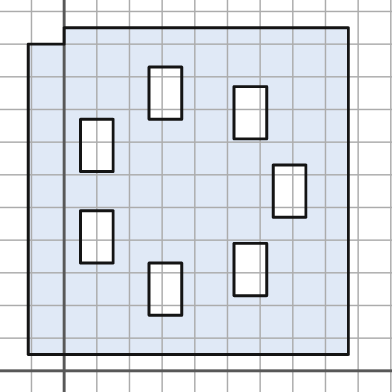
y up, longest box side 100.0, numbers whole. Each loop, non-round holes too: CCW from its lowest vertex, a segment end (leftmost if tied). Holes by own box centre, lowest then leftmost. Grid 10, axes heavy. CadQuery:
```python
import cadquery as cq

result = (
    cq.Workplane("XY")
    .moveTo(-11.0, 5.0)
    .lineTo(87.0, 5.0)
    .lineTo(87.0, 105.0)
    .lineTo(0.0, 105.0)
    .lineTo(0.0, 100.0)
    .lineTo(-11.0, 100.0)
    .close()
    .moveTo(26.0, 17.0)
    .lineTo(36.0, 17.0)
    .lineTo(36.0, 33.0)
    .lineTo(26.0, 33.0)
    .close()
    .moveTo(52.0, 23.0)
    .lineTo(62.0, 23.0)
    .lineTo(62.0, 39.0)
    .lineTo(52.0, 39.0)
    .close()
    .moveTo(5.0, 33.0)
    .lineTo(15.0, 33.0)
    .lineTo(15.0, 49.0)
    .lineTo(5.0, 49.0)
    .close()
    .moveTo(64.0, 47.0)
    .lineTo(74.0, 47.0)
    .lineTo(74.0, 63.0)
    .lineTo(64.0, 63.0)
    .close()
    .moveTo(5.0, 61.0)
    .lineTo(15.0, 61.0)
    .lineTo(15.0, 77.0)
    .lineTo(5.0, 77.0)
    .close()
    .moveTo(52.0, 71.0)
    .lineTo(62.0, 71.0)
    .lineTo(62.0, 87.0)
    .lineTo(52.0, 87.0)
    .close()
    .moveTo(26.0, 77.0)
    .lineTo(36.0, 77.0)
    .lineTo(36.0, 93.0)
    .lineTo(26.0, 93.0)
    .close()
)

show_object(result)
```